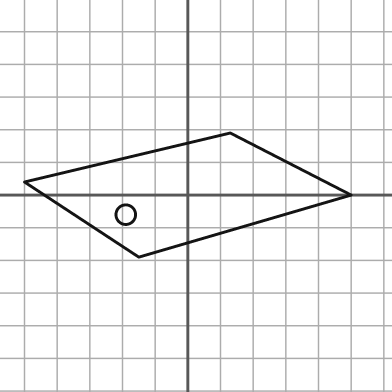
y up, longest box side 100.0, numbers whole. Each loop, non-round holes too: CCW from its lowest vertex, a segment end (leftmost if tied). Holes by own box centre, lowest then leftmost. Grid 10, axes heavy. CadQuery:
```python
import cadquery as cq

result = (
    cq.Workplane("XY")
    .moveTo(-15.0, -19.0)
    .lineTo(50.0, 0.0)
    .lineTo(13.0, 19.0)
    .lineTo(-50.0, 4.0)
    .close()
    .moveTo(-19.0, -6.0)
    .circle(3.0)
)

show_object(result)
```